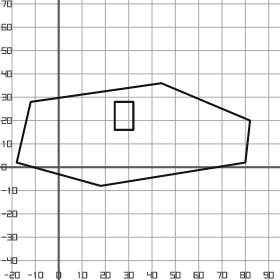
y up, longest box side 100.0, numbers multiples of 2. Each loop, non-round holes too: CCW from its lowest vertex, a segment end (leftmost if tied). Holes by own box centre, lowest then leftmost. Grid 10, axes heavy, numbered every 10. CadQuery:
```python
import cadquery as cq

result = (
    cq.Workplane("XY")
    .moveTo(18.0, -8.0)
    .lineTo(80.0, 2.0)
    .lineTo(82.0, 20.0)
    .lineTo(44.0, 36.0)
    .lineTo(-12.0, 28.0)
    .lineTo(-18.0, 2.0)
    .close()
    .moveTo(24.0, 16.0)
    .lineTo(32.0, 16.0)
    .lineTo(32.0, 28.0)
    .lineTo(24.0, 28.0)
    .close()
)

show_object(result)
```